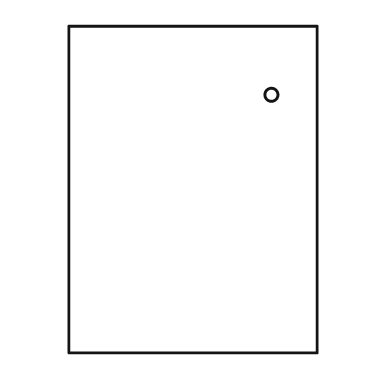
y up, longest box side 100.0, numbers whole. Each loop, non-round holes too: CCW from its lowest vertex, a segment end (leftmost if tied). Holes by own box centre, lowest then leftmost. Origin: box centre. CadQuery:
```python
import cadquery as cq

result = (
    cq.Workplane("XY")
    .moveTo(-38.0, -50.0)
    .lineTo(38.0, -50.0)
    .lineTo(38.0, 50.0)
    .lineTo(-38.0, 50.0)
    .close()
    .moveTo(24.0, 29.0)
    .circle(2.0)
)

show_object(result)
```